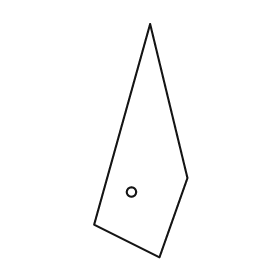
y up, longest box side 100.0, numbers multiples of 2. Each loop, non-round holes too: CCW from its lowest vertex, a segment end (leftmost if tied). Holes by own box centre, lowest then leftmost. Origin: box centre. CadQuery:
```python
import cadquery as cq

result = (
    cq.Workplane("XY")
    .moveTo(8.0, -50.0)
    .lineTo(20.0, -16.0)
    .lineTo(4.0, 50.0)
    .lineTo(-20.0, -36.0)
    .close()
    .moveTo(-4.0, -22.0)
    .circle(2.0)
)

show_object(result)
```